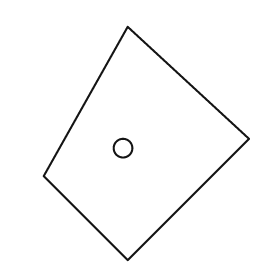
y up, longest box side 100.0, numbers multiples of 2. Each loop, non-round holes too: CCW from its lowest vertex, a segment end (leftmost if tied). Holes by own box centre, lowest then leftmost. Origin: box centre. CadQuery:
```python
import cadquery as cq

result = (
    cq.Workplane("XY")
    .moveTo(-8.0, -50.0)
    .lineTo(44.0, 2.0)
    .lineTo(-8.0, 50.0)
    .lineTo(-44.0, -14.0)
    .close()
    .moveTo(-10.0, -2.0)
    .circle(4.0)
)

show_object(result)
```